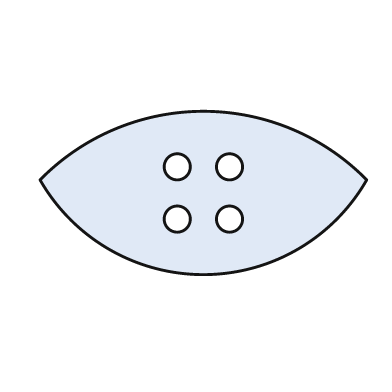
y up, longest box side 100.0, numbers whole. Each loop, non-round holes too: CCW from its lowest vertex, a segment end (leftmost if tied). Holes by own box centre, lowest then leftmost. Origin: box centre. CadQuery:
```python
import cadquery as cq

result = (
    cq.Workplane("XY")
    .moveTo(-50.0, 4.0)
    .threePointArc((0.0, -25.0), (50.0, 4.0))
    .threePointArc((0.0, 25.0), (-50.0, 4.0))
    .close()
    .moveTo(-8.0, -8.0)
    .circle(4.0)
    .moveTo(8.0, -8.0)
    .circle(4.0)
    .moveTo(-8.0, 8.0)
    .circle(4.0)
    .moveTo(8.0, 8.0)
    .circle(4.0)
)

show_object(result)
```